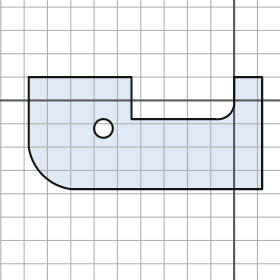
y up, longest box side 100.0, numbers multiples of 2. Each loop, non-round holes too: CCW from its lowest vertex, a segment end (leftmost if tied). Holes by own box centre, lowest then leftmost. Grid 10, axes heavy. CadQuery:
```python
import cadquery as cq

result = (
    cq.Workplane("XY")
    .moveTo(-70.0, -38.0)
    .lineTo(12.0, -38.0)
    .lineTo(12.0, 10.0)
    .lineTo(0.0, 10.0)
    .lineTo(0.0, 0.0)
    .threePointArc((-2.0, -6.0), (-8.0, -8.0))
    .lineTo(-44.0, -8.0)
    .lineTo(-44.0, 10.0)
    .lineTo(-88.0, 10.0)
    .lineTo(-88.0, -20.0)
    .threePointArc((-82.0, -32.0), (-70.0, -38.0))
    .close()
    .moveTo(-56.0, -12.0)
    .circle(4.0)
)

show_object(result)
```